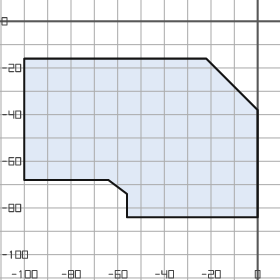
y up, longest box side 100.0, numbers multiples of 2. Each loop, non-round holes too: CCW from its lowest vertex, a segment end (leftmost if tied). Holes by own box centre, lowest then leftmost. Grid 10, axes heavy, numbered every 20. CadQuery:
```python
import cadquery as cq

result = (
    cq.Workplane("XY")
    .moveTo(-56.0, -84.0)
    .lineTo(0.0, -84.0)
    .lineTo(0.0, -38.0)
    .lineTo(-22.0, -16.0)
    .lineTo(-100.0, -16.0)
    .lineTo(-100.0, -68.0)
    .lineTo(-64.0, -68.0)
    .lineTo(-56.0, -74.0)
    .close()
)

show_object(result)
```